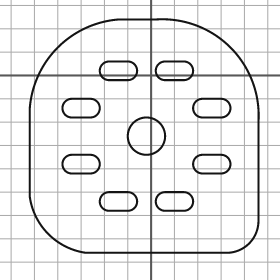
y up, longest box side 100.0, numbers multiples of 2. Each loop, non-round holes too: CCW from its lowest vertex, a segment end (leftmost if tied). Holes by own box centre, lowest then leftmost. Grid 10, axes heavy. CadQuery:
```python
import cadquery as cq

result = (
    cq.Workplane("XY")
    .moveTo(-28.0, -76.0)
    .lineTo(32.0, -76.0)
    .threePointArc((42.0, -72.0), (46.0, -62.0))
    .lineTo(46.0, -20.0)
    .threePointArc((34.0, 12.0), (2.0, 24.0))
    .lineTo(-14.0, 24.0)
    .threePointArc((-40.0, 12.0), (-52.0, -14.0))
    .lineTo(-52.0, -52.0)
    .threePointArc((-44.0, -68.0), (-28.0, -76.0))
    .close()
    .moveTo(-18.0, -58.0)
    .lineTo(-10.0, -58.0)
    .threePointArc((-6.0, -54.0), (-10.0, -50.0))
    .lineTo(-18.0, -50.0)
    .threePointArc((-22.0, -54.0), (-18.0, -58.0))
    .close()
    .moveTo(6.0, -58.0)
    .lineTo(14.0, -58.0)
    .threePointArc((18.0, -54.0), (14.0, -50.0))
    .lineTo(6.0, -50.0)
    .threePointArc((2.0, -54.0), (6.0, -58.0))
    .close()
    .moveTo(-34.0, -42.0)
    .lineTo(-26.0, -42.0)
    .threePointArc((-22.0, -38.0), (-26.0, -34.0))
    .lineTo(-34.0, -34.0)
    .threePointArc((-38.0, -38.0), (-34.0, -42.0))
    .close()
    .moveTo(22.0, -42.0)
    .lineTo(30.0, -42.0)
    .threePointArc((34.0, -38.0), (30.0, -34.0))
    .lineTo(22.0, -34.0)
    .threePointArc((18.0, -38.0), (22.0, -42.0))
    .close()
    .moveTo(-2.0, -26.0)
    .circle(8.0)
    .moveTo(-34.0, -18.0)
    .lineTo(-26.0, -18.0)
    .threePointArc((-22.0, -14.0), (-26.0, -10.0))
    .lineTo(-34.0, -10.0)
    .threePointArc((-38.0, -14.0), (-34.0, -18.0))
    .close()
    .moveTo(22.0, -18.0)
    .lineTo(30.0, -18.0)
    .threePointArc((34.0, -14.0), (30.0, -10.0))
    .lineTo(22.0, -10.0)
    .threePointArc((18.0, -14.0), (22.0, -18.0))
    .close()
    .moveTo(-18.0, -2.0)
    .lineTo(-10.0, -2.0)
    .threePointArc((-6.0, 2.0), (-10.0, 6.0))
    .lineTo(-18.0, 6.0)
    .threePointArc((-22.0, 2.0), (-18.0, -2.0))
    .close()
    .moveTo(6.0, -2.0)
    .lineTo(14.0, -2.0)
    .threePointArc((18.0, 2.0), (14.0, 6.0))
    .lineTo(6.0, 6.0)
    .threePointArc((2.0, 2.0), (6.0, -2.0))
    .close()
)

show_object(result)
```